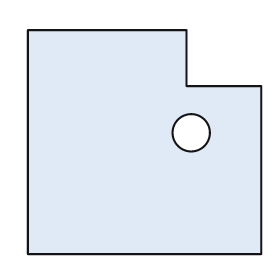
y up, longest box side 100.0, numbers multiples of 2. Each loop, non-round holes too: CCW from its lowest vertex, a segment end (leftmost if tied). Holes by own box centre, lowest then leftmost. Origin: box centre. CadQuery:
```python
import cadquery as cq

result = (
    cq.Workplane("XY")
    .moveTo(-50.0, -48.0)
    .lineTo(50.0, -48.0)
    .lineTo(50.0, 24.0)
    .lineTo(18.0, 24.0)
    .lineTo(18.0, 48.0)
    .lineTo(-50.0, 48.0)
    .close()
    .moveTo(20.0, 4.0)
    .circle(8.0)
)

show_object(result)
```